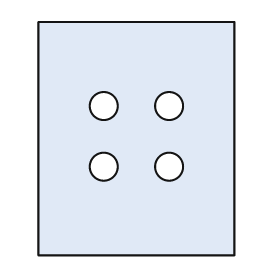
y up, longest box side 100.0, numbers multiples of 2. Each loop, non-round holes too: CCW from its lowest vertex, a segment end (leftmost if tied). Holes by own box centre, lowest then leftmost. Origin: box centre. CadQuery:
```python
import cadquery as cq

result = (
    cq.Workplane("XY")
    .moveTo(-42.0, -50.0)
    .lineTo(42.0, -50.0)
    .lineTo(42.0, 50.0)
    .lineTo(-42.0, 50.0)
    .close()
    .moveTo(-14.0, -12.0)
    .circle(6.0)
    .moveTo(14.0, -12.0)
    .circle(6.0)
    .moveTo(-14.0, 14.0)
    .circle(6.0)
    .moveTo(14.0, 14.0)
    .circle(6.0)
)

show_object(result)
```